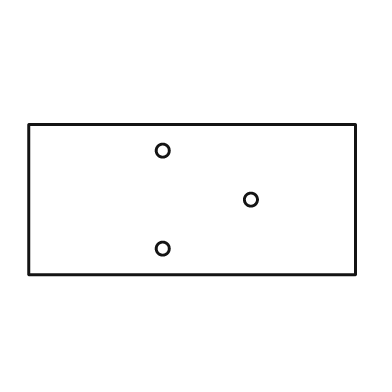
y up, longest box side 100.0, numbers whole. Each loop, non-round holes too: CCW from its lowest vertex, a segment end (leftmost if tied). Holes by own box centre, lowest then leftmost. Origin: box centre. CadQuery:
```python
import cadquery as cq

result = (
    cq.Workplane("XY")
    .moveTo(-50.0, -23.0)
    .lineTo(50.0, -23.0)
    .lineTo(50.0, 23.0)
    .lineTo(-50.0, 23.0)
    .close()
    .moveTo(-9.0, -15.0)
    .circle(2.0)
    .moveTo(18.0, 0.0)
    .circle(2.0)
    .moveTo(-9.0, 15.0)
    .circle(2.0)
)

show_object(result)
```